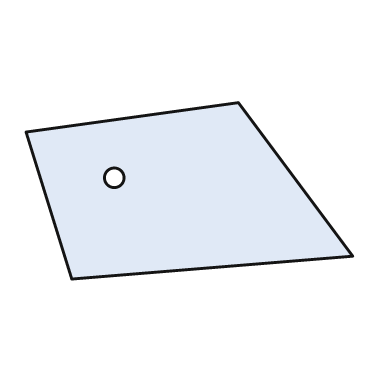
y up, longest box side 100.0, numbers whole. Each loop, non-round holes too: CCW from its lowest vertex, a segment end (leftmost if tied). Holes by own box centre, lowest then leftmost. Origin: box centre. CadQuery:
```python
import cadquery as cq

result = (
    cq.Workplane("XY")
    .moveTo(-36.0, -27.0)
    .lineTo(50.0, -20.0)
    .lineTo(15.0, 27.0)
    .lineTo(-50.0, 18.0)
    .close()
    .moveTo(-23.0, 4.0)
    .circle(3.0)
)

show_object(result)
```